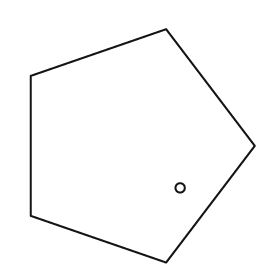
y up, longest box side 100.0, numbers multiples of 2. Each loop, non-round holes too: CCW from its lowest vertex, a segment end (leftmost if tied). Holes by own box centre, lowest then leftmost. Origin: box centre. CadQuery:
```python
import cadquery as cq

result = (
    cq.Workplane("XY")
    .moveTo(10.0, -50.0)
    .lineTo(48.0, 0.0)
    .lineTo(10.0, 50.0)
    .lineTo(-48.0, 30.0)
    .lineTo(-48.0, -30.0)
    .close()
    .moveTo(16.0, -18.0)
    .circle(2.0)
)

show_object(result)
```